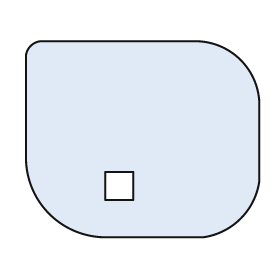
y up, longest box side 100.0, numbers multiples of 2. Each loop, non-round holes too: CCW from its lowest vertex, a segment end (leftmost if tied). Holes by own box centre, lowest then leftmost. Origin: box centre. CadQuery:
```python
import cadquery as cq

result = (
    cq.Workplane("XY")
    .moveTo(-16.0, -42.0)
    .lineTo(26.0, -42.0)
    .threePointArc((42.0, -34.0), (50.0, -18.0))
    .lineTo(50.0, 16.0)
    .threePointArc((42.0, 34.0), (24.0, 42.0))
    .lineTo(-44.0, 42.0)
    .threePointArc((-48.0, 40.0), (-50.0, 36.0))
    .lineTo(-50.0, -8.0)
    .threePointArc((-40.0, -32.0), (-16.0, -42.0))
    .close()
    .moveTo(-16.0, -26.0)
    .lineTo(-4.0, -26.0)
    .lineTo(-4.0, -14.0)
    .lineTo(-16.0, -14.0)
    .close()
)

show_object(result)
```